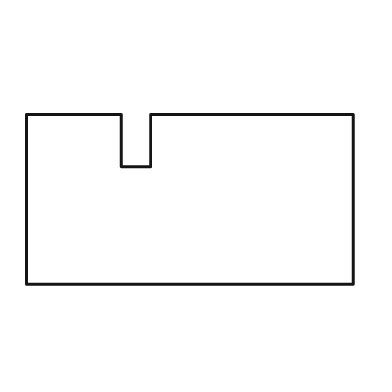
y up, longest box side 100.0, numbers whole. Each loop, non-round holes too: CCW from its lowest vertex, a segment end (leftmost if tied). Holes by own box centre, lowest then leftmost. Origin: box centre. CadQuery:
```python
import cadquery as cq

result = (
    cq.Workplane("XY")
    .moveTo(-50.0, -26.0)
    .lineTo(50.0, -26.0)
    .lineTo(50.0, 26.0)
    .lineTo(-12.0, 26.0)
    .lineTo(-12.0, 10.0)
    .lineTo(-21.0, 10.0)
    .lineTo(-21.0, 26.0)
    .lineTo(-50.0, 26.0)
    .close()
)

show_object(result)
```